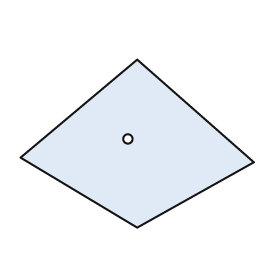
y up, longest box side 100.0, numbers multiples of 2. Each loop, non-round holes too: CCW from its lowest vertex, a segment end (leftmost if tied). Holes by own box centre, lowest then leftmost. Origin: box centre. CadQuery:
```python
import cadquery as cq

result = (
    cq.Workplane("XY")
    .moveTo(0.0, -36.0)
    .lineTo(50.0, -8.0)
    .lineTo(0.0, 36.0)
    .lineTo(-50.0, -6.0)
    .close()
    .moveTo(-4.0, 2.0)
    .circle(2.0)
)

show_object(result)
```